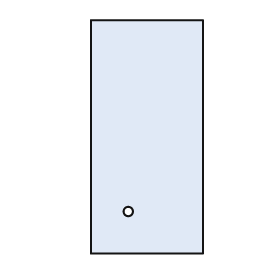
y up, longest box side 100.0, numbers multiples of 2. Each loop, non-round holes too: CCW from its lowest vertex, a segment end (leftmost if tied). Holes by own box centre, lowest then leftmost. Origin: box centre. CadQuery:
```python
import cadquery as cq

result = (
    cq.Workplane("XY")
    .moveTo(-24.0, -50.0)
    .lineTo(24.0, -50.0)
    .lineTo(24.0, 50.0)
    .lineTo(-24.0, 50.0)
    .close()
    .moveTo(-8.0, -32.0)
    .circle(2.0)
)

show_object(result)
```